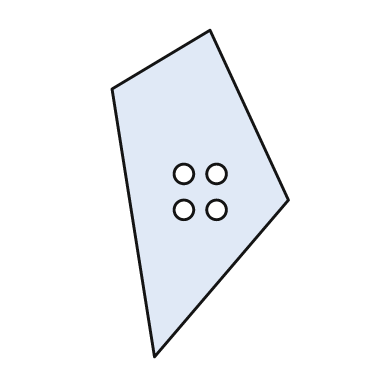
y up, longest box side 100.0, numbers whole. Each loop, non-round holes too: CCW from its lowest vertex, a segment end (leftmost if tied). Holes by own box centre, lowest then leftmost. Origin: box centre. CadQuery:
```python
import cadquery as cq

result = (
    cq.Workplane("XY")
    .moveTo(-14.0, -50.0)
    .lineTo(27.0, -2.0)
    .lineTo(3.0, 50.0)
    .lineTo(-27.0, 32.0)
    .close()
    .moveTo(-5.0, -5.0)
    .circle(3.0)
    .moveTo(5.0, -5.0)
    .circle(3.0)
    .moveTo(-5.0, 6.0)
    .circle(3.0)
    .moveTo(5.0, 6.0)
    .circle(3.0)
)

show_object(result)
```